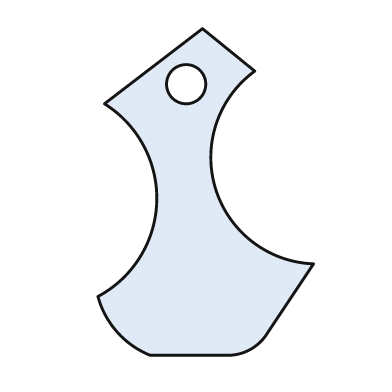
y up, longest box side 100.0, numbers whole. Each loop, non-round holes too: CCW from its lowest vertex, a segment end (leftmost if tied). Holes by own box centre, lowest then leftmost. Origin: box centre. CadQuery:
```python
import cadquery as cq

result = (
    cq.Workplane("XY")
    .moveTo(-17.0, -50.0)
    .lineTo(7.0, -50.0)
    .threePointArc((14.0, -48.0), (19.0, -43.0))
    .lineTo(33.0, -22.0)
    .threePointArc((3.0, 1.0), (15.0, 37.0))
    .lineTo(-1.0, 50.0)
    .lineTo(-31.0, 27.0)
    .threePointArc((-15.0, -3.0), (-33.0, -32.0))
    .threePointArc((-27.0, -43.0), (-17.0, -50.0))
    .close()
    .moveTo(-6.0, 33.0)
    .circle(6.0)
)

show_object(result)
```